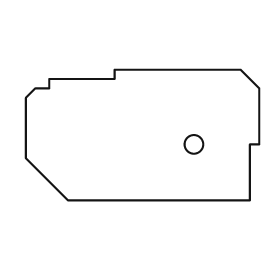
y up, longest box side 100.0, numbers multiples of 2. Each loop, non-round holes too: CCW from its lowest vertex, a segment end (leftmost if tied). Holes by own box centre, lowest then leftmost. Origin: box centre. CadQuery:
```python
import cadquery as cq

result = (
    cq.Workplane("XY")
    .moveTo(-32.0, -28.0)
    .lineTo(46.0, -28.0)
    .lineTo(46.0, -4.0)
    .lineTo(50.0, -4.0)
    .lineTo(50.0, 20.0)
    .lineTo(42.0, 28.0)
    .lineTo(-12.0, 28.0)
    .lineTo(-12.0, 24.0)
    .lineTo(-40.0, 24.0)
    .lineTo(-40.0, 20.0)
    .lineTo(-46.0, 20.0)
    .lineTo(-50.0, 16.0)
    .lineTo(-50.0, -10.0)
    .close()
    .moveTo(22.0, -4.0)
    .circle(4.0)
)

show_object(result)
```